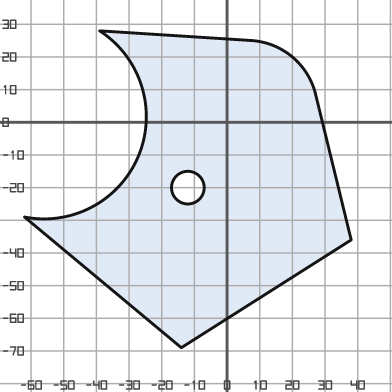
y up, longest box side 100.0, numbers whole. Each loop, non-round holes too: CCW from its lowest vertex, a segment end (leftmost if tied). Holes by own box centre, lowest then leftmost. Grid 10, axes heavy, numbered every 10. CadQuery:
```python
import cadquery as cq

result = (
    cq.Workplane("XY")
    .moveTo(-14.0, -69.0)
    .lineTo(38.0, -36.0)
    .lineTo(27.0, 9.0)
    .threePointArc((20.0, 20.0), (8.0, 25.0))
    .lineTo(-39.0, 28.0)
    .threePointArc((-27.0, -10.0), (-62.0, -29.0))
    .close()
    .moveTo(-12.0, -20.0)
    .circle(5.0)
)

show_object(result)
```